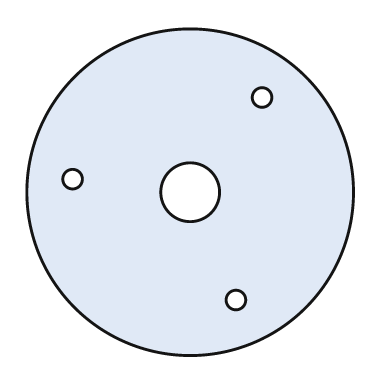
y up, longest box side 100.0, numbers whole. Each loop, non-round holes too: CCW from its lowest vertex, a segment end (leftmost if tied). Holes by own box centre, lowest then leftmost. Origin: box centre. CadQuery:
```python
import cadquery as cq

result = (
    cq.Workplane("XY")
    .moveTo(0.0, 0.0)
    .circle(50.0)
    .moveTo(14.0, -33.0)
    .circle(3.0)
    .moveTo(0.0, 0.0)
    .circle(9.0)
    .moveTo(-36.0, 4.0)
    .circle(3.0)
    .moveTo(22.0, 29.0)
    .circle(3.0)
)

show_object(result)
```